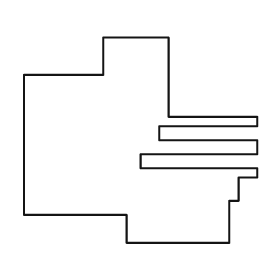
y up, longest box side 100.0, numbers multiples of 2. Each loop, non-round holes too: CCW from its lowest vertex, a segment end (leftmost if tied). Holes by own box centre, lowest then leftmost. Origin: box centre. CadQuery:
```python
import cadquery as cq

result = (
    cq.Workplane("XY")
    .moveTo(-6.0, -44.0)
    .lineTo(38.0, -44.0)
    .lineTo(38.0, -26.0)
    .lineTo(42.0, -26.0)
    .lineTo(42.0, -16.0)
    .lineTo(50.0, -16.0)
    .lineTo(50.0, -12.0)
    .lineTo(0.0, -12.0)
    .lineTo(0.0, -6.0)
    .lineTo(50.0, -6.0)
    .lineTo(50.0, 0.0)
    .lineTo(8.0, 0.0)
    .lineTo(8.0, 6.0)
    .lineTo(50.0, 6.0)
    .lineTo(50.0, 10.0)
    .lineTo(12.0, 10.0)
    .lineTo(12.0, 44.0)
    .lineTo(-16.0, 44.0)
    .lineTo(-16.0, 28.0)
    .lineTo(-50.0, 28.0)
    .lineTo(-50.0, -32.0)
    .lineTo(-6.0, -32.0)
    .close()
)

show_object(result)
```